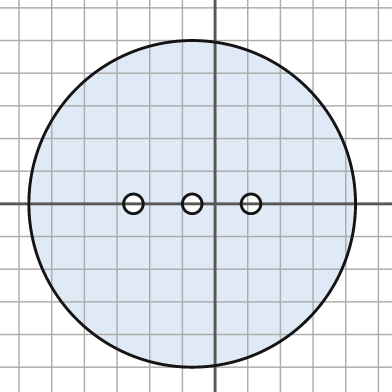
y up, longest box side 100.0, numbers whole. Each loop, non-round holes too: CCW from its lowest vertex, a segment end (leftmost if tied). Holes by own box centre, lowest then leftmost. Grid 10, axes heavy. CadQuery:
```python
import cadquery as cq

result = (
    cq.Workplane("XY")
    .moveTo(-7.0, 0.0)
    .circle(50.0)
    .moveTo(-25.0, 0.0)
    .circle(3.0)
    .moveTo(-7.0, 0.0)
    .circle(3.0)
    .moveTo(11.0, 0.0)
    .circle(3.0)
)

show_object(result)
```